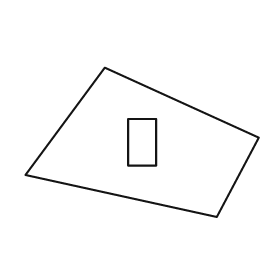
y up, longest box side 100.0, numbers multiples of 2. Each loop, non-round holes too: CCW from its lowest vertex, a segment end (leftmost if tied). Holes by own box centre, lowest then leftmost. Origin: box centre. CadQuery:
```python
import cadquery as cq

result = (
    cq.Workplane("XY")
    .moveTo(32.0, -32.0)
    .lineTo(50.0, 2.0)
    .lineTo(-16.0, 32.0)
    .lineTo(-50.0, -14.0)
    .close()
    .moveTo(-6.0, -10.0)
    .lineTo(6.0, -10.0)
    .lineTo(6.0, 10.0)
    .lineTo(-6.0, 10.0)
    .close()
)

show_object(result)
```